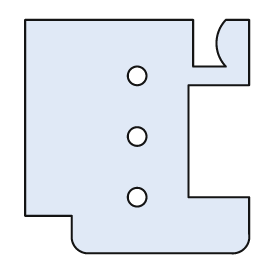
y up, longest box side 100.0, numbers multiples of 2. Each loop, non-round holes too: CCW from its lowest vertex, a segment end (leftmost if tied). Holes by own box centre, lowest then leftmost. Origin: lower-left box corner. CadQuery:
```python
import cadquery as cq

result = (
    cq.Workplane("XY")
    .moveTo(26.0, 0.0)
    .lineTo(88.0, 0.0)
    .threePointArc((94.0, 2.0), (96.0, 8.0))
    .lineTo(96.0, 24.0)
    .lineTo(70.0, 24.0)
    .lineTo(70.0, 72.0)
    .lineTo(96.0, 72.0)
    .lineTo(96.0, 100.0)
    .lineTo(86.0, 100.0)
    .threePointArc((82.0, 90.0), (86.0, 80.0))
    .lineTo(72.0, 80.0)
    .lineTo(72.0, 100.0)
    .lineTo(0.0, 100.0)
    .lineTo(0.0, 16.0)
    .lineTo(20.0, 16.0)
    .lineTo(20.0, 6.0)
    .threePointArc((22.0, 2.0), (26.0, 0.0))
    .close()
    .moveTo(48.0, 24.0)
    .circle(4.0)
    .moveTo(48.0, 50.0)
    .circle(4.0)
    .moveTo(48.0, 76.0)
    .circle(4.0)
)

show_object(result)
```